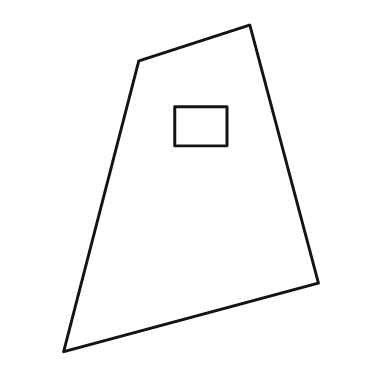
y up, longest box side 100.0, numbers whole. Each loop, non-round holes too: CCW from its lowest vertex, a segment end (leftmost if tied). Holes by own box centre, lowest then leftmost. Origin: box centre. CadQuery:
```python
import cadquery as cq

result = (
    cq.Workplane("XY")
    .moveTo(-39.0, -50.0)
    .lineTo(39.0, -29.0)
    .lineTo(18.0, 50.0)
    .lineTo(-16.0, 39.0)
    .close()
    .moveTo(-5.0, 13.0)
    .lineTo(11.0, 13.0)
    .lineTo(11.0, 25.0)
    .lineTo(-5.0, 25.0)
    .close()
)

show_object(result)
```